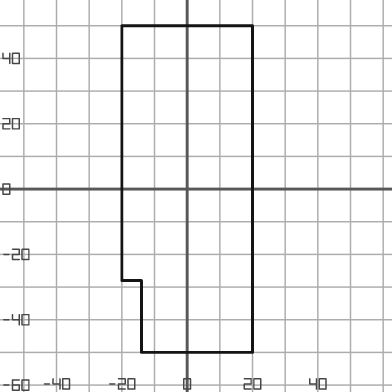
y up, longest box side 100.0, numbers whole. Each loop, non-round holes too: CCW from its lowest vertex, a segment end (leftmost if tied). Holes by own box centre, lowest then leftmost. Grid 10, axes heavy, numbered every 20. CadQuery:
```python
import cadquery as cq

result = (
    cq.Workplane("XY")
    .moveTo(-14.0, -50.0)
    .lineTo(20.0, -50.0)
    .lineTo(20.0, 50.0)
    .lineTo(-20.0, 50.0)
    .lineTo(-20.0, -28.0)
    .lineTo(-14.0, -28.0)
    .close()
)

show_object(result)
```